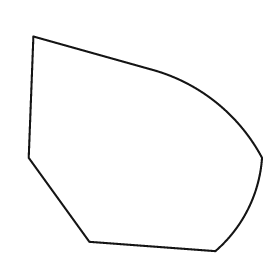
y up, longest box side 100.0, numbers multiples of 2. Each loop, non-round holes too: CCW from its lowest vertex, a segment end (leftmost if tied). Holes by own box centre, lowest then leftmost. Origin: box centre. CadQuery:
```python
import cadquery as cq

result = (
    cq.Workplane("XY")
    .moveTo(30.0, -46.0)
    .threePointArc((44.0, -28.0), (50.0, -6.0))
    .threePointArc((30.0, 18.0), (2.0, 32.0))
    .lineTo(-48.0, 46.0)
    .lineTo(-50.0, -6.0)
    .lineTo(-24.0, -42.0)
    .close()
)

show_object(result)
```